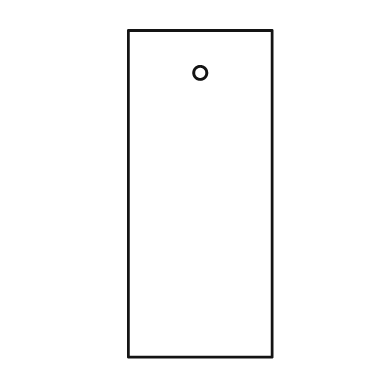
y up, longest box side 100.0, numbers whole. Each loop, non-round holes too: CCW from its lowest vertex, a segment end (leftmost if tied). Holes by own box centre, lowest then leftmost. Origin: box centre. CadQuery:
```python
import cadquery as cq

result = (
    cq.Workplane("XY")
    .moveTo(-22.0, -50.0)
    .lineTo(22.0, -50.0)
    .lineTo(22.0, 50.0)
    .lineTo(-22.0, 50.0)
    .close()
    .moveTo(0.0, 37.0)
    .circle(2.0)
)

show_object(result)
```